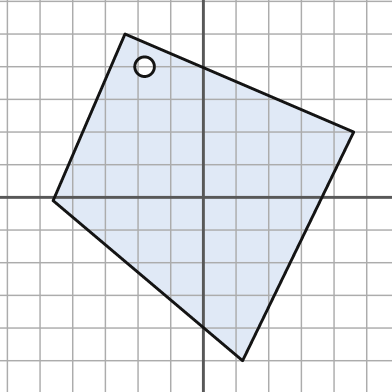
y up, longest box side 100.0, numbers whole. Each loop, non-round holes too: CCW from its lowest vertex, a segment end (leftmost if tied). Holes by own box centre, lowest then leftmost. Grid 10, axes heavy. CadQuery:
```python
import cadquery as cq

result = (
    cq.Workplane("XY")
    .moveTo(12.0, -50.0)
    .lineTo(46.0, 20.0)
    .lineTo(-24.0, 50.0)
    .lineTo(-46.0, -1.0)
    .close()
    .moveTo(-18.0, 40.0)
    .circle(3.0)
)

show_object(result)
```